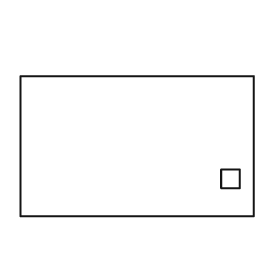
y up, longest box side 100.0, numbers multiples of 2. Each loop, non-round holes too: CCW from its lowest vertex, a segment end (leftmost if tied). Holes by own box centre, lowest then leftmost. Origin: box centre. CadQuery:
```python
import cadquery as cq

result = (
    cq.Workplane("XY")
    .moveTo(-50.0, -30.0)
    .lineTo(50.0, -30.0)
    .lineTo(50.0, 30.0)
    .lineTo(-50.0, 30.0)
    .close()
    .moveTo(36.0, -18.0)
    .lineTo(44.0, -18.0)
    .lineTo(44.0, -10.0)
    .lineTo(36.0, -10.0)
    .close()
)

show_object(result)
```